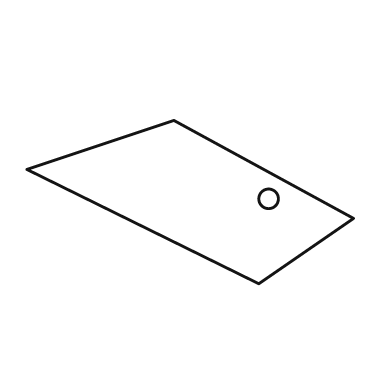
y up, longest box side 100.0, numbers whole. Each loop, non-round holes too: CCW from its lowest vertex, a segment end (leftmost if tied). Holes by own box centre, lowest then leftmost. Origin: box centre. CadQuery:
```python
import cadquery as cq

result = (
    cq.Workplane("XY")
    .moveTo(21.0, -25.0)
    .lineTo(50.0, -5.0)
    .lineTo(-5.0, 25.0)
    .lineTo(-50.0, 10.0)
    .close()
    .moveTo(24.0, 1.0)
    .circle(3.0)
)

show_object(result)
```